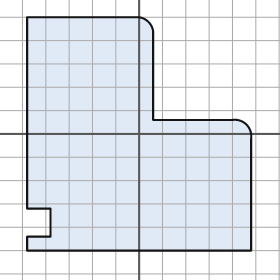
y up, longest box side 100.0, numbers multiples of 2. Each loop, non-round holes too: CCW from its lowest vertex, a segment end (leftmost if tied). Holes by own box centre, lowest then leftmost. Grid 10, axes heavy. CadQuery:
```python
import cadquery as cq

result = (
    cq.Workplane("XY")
    .moveTo(-48.0, -50.0)
    .lineTo(48.0, -50.0)
    .lineTo(48.0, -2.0)
    .threePointArc((46.0, 4.0), (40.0, 6.0))
    .lineTo(6.0, 6.0)
    .lineTo(6.0, 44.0)
    .threePointArc((4.0, 48.0), (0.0, 50.0))
    .lineTo(-48.0, 50.0)
    .lineTo(-48.0, -32.0)
    .lineTo(-38.0, -32.0)
    .lineTo(-38.0, -44.0)
    .lineTo(-48.0, -44.0)
    .close()
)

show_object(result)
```